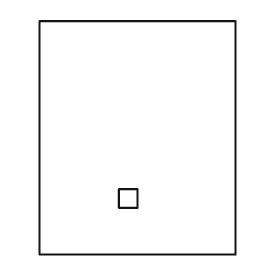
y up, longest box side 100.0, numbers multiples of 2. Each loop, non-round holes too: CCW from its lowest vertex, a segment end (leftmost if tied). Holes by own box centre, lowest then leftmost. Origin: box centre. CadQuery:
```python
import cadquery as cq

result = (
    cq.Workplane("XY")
    .moveTo(-42.0, -50.0)
    .lineTo(42.0, -50.0)
    .lineTo(42.0, 50.0)
    .lineTo(-42.0, 50.0)
    .close()
    .moveTo(-8.0, -30.0)
    .lineTo(0.0, -30.0)
    .lineTo(0.0, -22.0)
    .lineTo(-8.0, -22.0)
    .close()
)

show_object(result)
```